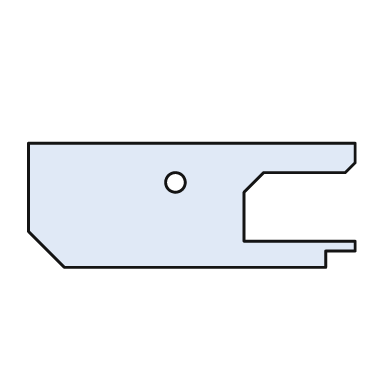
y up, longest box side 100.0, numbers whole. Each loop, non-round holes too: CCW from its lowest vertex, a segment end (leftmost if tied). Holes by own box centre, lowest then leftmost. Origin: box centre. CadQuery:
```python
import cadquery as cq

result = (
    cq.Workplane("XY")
    .moveTo(-39.0, -19.0)
    .lineTo(41.0, -19.0)
    .lineTo(41.0, -14.0)
    .lineTo(50.0, -14.0)
    .lineTo(50.0, -11.0)
    .lineTo(16.0, -11.0)
    .lineTo(16.0, 4.0)
    .lineTo(22.0, 10.0)
    .lineTo(47.0, 10.0)
    .lineTo(50.0, 13.0)
    .lineTo(50.0, 19.0)
    .lineTo(-50.0, 19.0)
    .lineTo(-50.0, -8.0)
    .close()
    .moveTo(-5.0, 7.0)
    .circle(3.0)
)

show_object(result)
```